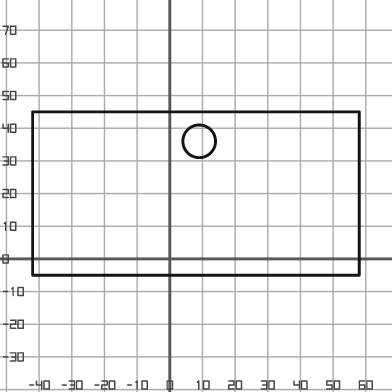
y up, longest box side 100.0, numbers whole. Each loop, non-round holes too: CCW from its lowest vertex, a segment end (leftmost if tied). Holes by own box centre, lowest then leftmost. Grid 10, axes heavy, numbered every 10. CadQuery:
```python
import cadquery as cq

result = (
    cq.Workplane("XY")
    .moveTo(-42.0, -5.0)
    .lineTo(58.0, -5.0)
    .lineTo(58.0, 45.0)
    .lineTo(-42.0, 45.0)
    .close()
    .moveTo(9.0, 36.0)
    .circle(5.0)
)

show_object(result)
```